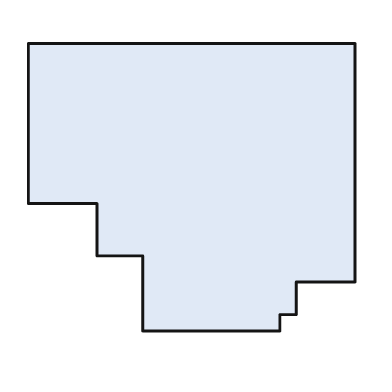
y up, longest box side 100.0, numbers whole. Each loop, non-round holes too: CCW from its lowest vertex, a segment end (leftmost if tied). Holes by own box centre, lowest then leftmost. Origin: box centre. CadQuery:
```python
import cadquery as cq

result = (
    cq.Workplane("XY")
    .moveTo(-15.0, -44.0)
    .lineTo(27.0, -44.0)
    .lineTo(27.0, -39.0)
    .lineTo(32.0, -39.0)
    .lineTo(32.0, -29.0)
    .lineTo(50.0, -29.0)
    .lineTo(50.0, 44.0)
    .lineTo(-50.0, 44.0)
    .lineTo(-50.0, -5.0)
    .lineTo(-29.0, -5.0)
    .lineTo(-29.0, -21.0)
    .lineTo(-15.0, -21.0)
    .close()
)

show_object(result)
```